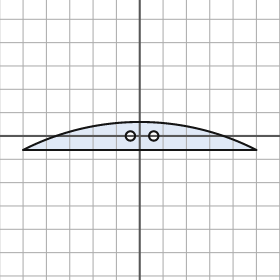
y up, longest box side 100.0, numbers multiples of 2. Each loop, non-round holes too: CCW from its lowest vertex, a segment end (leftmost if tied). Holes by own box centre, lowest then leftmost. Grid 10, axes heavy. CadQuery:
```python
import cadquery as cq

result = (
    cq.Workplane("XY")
    .moveTo(-50.0, -6.0)
    .lineTo(50.0, -6.0)
    .threePointArc((0.0, 6.0), (-50.0, -6.0))
    .close()
    .moveTo(-4.0, 0.0)
    .circle(2.0)
    .moveTo(6.0, 0.0)
    .circle(2.0)
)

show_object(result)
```